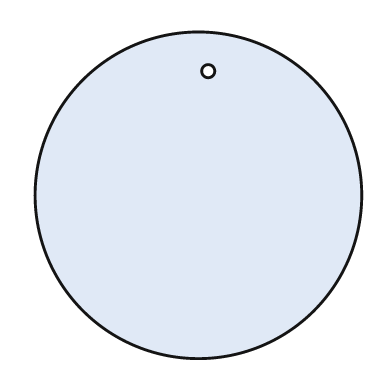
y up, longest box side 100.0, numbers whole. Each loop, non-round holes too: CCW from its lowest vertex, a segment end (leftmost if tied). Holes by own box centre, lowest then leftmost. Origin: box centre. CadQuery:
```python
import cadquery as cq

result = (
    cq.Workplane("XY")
    .moveTo(0.0, 0.0)
    .circle(50.0)
    .moveTo(3.0, 38.0)
    .circle(2.0)
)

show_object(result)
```